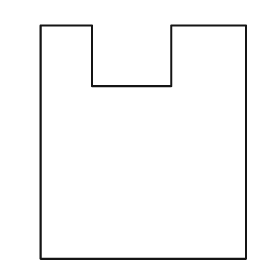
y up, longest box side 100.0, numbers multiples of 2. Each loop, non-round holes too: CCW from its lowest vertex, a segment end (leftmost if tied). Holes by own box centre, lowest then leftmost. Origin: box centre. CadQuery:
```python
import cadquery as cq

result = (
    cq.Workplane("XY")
    .moveTo(-44.0, -50.0)
    .lineTo(44.0, -50.0)
    .lineTo(44.0, 50.0)
    .lineTo(12.0, 50.0)
    .lineTo(12.0, 24.0)
    .lineTo(-22.0, 24.0)
    .lineTo(-22.0, 50.0)
    .lineTo(-44.0, 50.0)
    .close()
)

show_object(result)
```